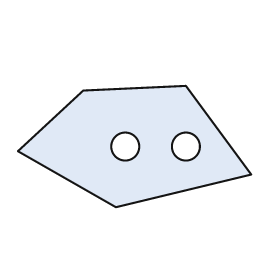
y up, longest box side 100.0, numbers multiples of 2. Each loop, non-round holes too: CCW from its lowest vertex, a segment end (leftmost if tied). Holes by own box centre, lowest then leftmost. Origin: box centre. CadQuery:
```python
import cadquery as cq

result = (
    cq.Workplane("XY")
    .moveTo(-8.0, -26.0)
    .lineTo(50.0, -12.0)
    .lineTo(22.0, 26.0)
    .lineTo(-22.0, 24.0)
    .lineTo(-50.0, -2.0)
    .close()
    .moveTo(-4.0, 0.0)
    .circle(6.0)
    .moveTo(22.0, 0.0)
    .circle(6.0)
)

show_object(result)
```